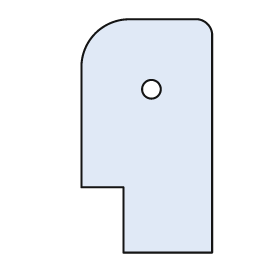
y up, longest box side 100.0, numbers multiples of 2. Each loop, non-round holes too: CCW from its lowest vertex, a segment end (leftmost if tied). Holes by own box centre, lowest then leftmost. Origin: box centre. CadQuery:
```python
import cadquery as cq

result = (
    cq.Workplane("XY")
    .moveTo(-10.0, -50.0)
    .lineTo(28.0, -50.0)
    .lineTo(28.0, 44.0)
    .threePointArc((26.0, 48.0), (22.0, 50.0))
    .lineTo(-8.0, 50.0)
    .threePointArc((-22.0, 44.0), (-28.0, 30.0))
    .lineTo(-28.0, -22.0)
    .lineTo(-10.0, -22.0)
    .close()
    .moveTo(2.0, 20.0)
    .circle(4.0)
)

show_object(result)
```